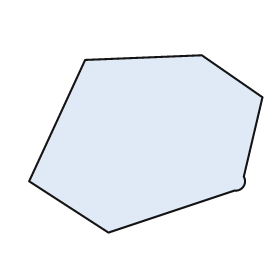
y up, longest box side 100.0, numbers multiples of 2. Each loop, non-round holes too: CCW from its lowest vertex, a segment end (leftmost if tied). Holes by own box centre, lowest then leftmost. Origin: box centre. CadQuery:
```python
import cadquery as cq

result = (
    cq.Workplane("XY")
    .moveTo(-16.0, -38.0)
    .lineTo(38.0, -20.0)
    .threePointArc((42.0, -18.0), (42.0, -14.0))
    .lineTo(50.0, 20.0)
    .lineTo(24.0, 38.0)
    .lineTo(-26.0, 36.0)
    .lineTo(-50.0, -16.0)
    .close()
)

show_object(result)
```